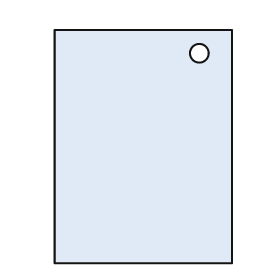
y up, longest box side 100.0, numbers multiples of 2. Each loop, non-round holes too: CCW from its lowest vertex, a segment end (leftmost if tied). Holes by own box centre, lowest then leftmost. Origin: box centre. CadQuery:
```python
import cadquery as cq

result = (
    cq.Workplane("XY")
    .moveTo(-38.0, -50.0)
    .lineTo(38.0, -50.0)
    .lineTo(38.0, 50.0)
    .lineTo(-38.0, 50.0)
    .close()
    .moveTo(24.0, 40.0)
    .circle(4.0)
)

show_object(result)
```